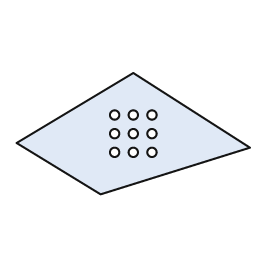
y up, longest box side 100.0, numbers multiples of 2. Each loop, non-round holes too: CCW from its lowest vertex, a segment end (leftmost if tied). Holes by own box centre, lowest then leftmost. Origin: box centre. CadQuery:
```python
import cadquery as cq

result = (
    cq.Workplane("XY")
    .moveTo(-14.0, -26.0)
    .lineTo(50.0, -6.0)
    .lineTo(0.0, 26.0)
    .lineTo(-50.0, -4.0)
    .close()
    .moveTo(-8.0, -8.0)
    .circle(2.0)
    .moveTo(0.0, -8.0)
    .circle(2.0)
    .moveTo(8.0, -8.0)
    .circle(2.0)
    .moveTo(-8.0, 0.0)
    .circle(2.0)
    .moveTo(0.0, 0.0)
    .circle(2.0)
    .moveTo(8.0, 0.0)
    .circle(2.0)
    .moveTo(-8.0, 8.0)
    .circle(2.0)
    .moveTo(0.0, 8.0)
    .circle(2.0)
    .moveTo(8.0, 8.0)
    .circle(2.0)
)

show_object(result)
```